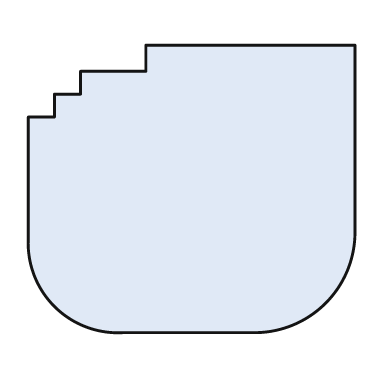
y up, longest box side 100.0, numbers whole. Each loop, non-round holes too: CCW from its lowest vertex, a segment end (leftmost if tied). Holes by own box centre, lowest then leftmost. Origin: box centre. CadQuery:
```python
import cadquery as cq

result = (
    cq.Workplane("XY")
    .moveTo(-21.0, -44.0)
    .lineTo(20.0, -44.0)
    .threePointArc((41.0, -35.0), (50.0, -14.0))
    .lineTo(50.0, 44.0)
    .lineTo(-14.0, 44.0)
    .lineTo(-14.0, 36.0)
    .lineTo(-34.0, 36.0)
    .lineTo(-34.0, 29.0)
    .lineTo(-42.0, 29.0)
    .lineTo(-42.0, 22.0)
    .lineTo(-50.0, 22.0)
    .lineTo(-50.0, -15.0)
    .threePointArc((-42.0, -36.0), (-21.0, -44.0))
    .close()
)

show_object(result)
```